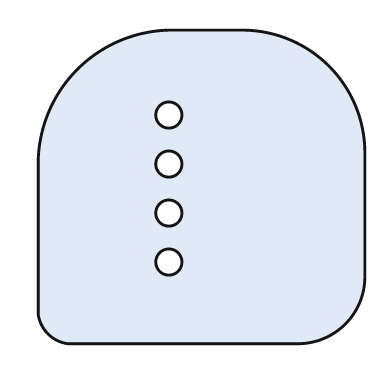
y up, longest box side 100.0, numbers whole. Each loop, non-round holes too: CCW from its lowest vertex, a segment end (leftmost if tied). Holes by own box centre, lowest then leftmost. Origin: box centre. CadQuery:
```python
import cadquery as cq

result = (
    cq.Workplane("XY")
    .moveTo(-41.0, -48.0)
    .lineTo(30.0, -48.0)
    .threePointArc((44.0, -42.0), (50.0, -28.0))
    .lineTo(50.0, 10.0)
    .threePointArc((39.0, 37.0), (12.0, 48.0))
    .lineTo(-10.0, 48.0)
    .threePointArc((-38.0, 36.0), (-50.0, 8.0))
    .lineTo(-50.0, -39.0)
    .threePointArc((-47.0, -45.0), (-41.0, -48.0))
    .close()
    .moveTo(-10.0, -23.0)
    .circle(4.0)
    .moveTo(-10.0, -8.0)
    .circle(4.0)
    .moveTo(-10.0, 7.0)
    .circle(4.0)
    .moveTo(-10.0, 22.0)
    .circle(4.0)
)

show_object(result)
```